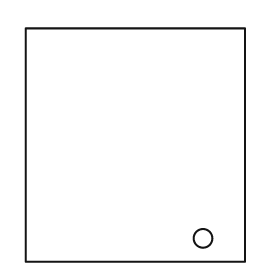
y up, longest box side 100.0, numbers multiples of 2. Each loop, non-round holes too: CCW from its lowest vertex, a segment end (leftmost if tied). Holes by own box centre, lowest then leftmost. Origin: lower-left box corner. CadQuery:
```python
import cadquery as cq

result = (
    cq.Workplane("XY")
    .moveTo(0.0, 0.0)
    .lineTo(94.0, 0.0)
    .lineTo(94.0, 100.0)
    .lineTo(0.0, 100.0)
    .close()
    .moveTo(76.0, 10.0)
    .circle(4.0)
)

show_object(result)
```